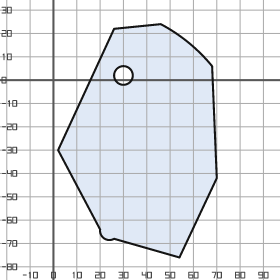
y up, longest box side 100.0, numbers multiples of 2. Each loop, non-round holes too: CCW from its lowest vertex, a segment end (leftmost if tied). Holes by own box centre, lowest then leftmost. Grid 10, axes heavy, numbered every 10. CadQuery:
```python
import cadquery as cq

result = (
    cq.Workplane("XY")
    .moveTo(54.0, -76.0)
    .lineTo(70.0, -42.0)
    .lineTo(68.0, 6.0)
    .threePointArc((58.0, 16.0), (46.0, 24.0))
    .lineTo(26.0, 22.0)
    .lineTo(2.0, -30.0)
    .lineTo(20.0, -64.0)
    .threePointArc((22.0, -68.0), (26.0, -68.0))
    .close()
    .moveTo(30.0, 2.0)
    .circle(4.0)
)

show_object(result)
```